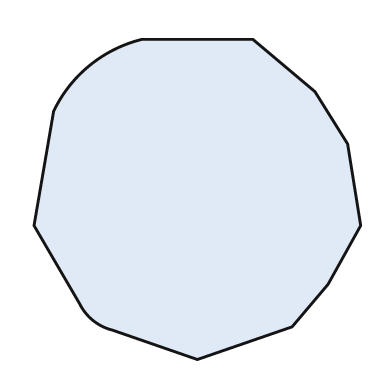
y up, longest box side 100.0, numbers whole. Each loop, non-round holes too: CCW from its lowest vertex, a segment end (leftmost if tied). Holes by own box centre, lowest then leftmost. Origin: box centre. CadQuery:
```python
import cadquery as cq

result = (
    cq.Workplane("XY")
    .moveTo(0.0, -49.0)
    .lineTo(29.0, -39.0)
    .lineTo(40.0, -26.0)
    .lineTo(50.0, -8.0)
    .lineTo(46.0, 17.0)
    .lineTo(36.0, 33.0)
    .lineTo(17.0, 49.0)
    .lineTo(-17.0, 49.0)
    .threePointArc((-33.0, 41.0), (-44.0, 27.0))
    .lineTo(-50.0, -8.0)
    .lineTo(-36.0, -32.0)
    .threePointArc((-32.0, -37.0), (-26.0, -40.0))
    .close()
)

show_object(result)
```